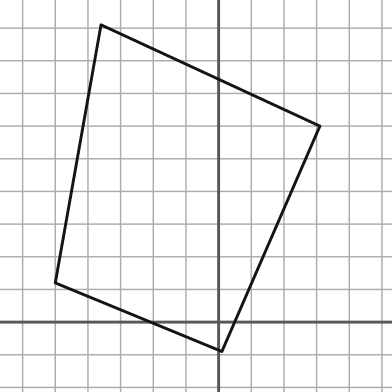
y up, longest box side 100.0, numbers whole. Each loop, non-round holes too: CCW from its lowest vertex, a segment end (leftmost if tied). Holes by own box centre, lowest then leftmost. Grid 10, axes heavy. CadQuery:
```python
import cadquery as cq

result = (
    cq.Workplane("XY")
    .moveTo(1.0, -9.0)
    .lineTo(31.0, 60.0)
    .lineTo(-36.0, 91.0)
    .lineTo(-50.0, 12.0)
    .close()
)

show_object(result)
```